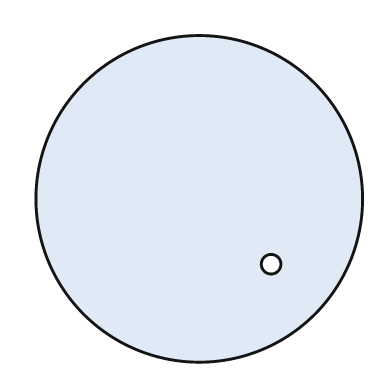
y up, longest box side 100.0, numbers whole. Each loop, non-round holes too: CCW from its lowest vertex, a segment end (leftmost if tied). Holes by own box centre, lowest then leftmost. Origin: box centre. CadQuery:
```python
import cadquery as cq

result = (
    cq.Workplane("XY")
    .moveTo(0.0, 0.0)
    .circle(50.0)
    .moveTo(22.0, -20.0)
    .circle(3.0)
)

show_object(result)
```